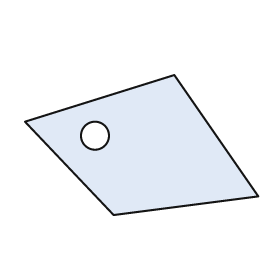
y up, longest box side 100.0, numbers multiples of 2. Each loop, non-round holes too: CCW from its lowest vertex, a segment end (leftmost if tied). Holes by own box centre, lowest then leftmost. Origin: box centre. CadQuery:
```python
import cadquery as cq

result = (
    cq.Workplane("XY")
    .moveTo(-12.0, -30.0)
    .lineTo(50.0, -22.0)
    .lineTo(14.0, 30.0)
    .lineTo(-50.0, 10.0)
    .close()
    .moveTo(-20.0, 4.0)
    .circle(6.0)
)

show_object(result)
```